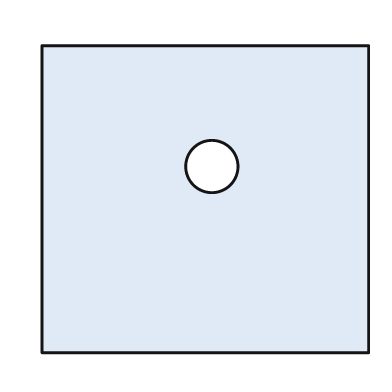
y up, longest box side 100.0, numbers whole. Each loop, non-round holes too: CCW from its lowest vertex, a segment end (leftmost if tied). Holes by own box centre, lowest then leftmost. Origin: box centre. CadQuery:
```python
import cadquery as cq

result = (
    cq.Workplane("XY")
    .moveTo(-50.0, -47.0)
    .lineTo(50.0, -47.0)
    .lineTo(50.0, 47.0)
    .lineTo(-50.0, 47.0)
    .close()
    .moveTo(2.0, 10.0)
    .circle(8.0)
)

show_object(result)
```